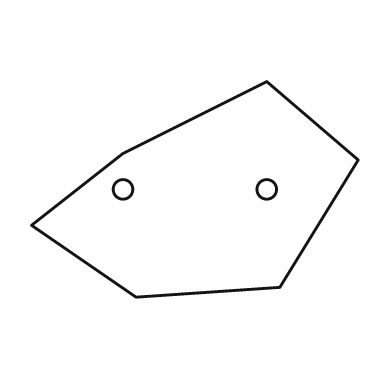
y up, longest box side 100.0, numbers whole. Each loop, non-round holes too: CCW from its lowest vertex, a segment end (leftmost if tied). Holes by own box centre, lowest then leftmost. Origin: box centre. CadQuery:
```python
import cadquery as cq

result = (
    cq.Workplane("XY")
    .moveTo(-18.0, -33.0)
    .lineTo(26.0, -30.0)
    .lineTo(50.0, 9.0)
    .lineTo(22.0, 33.0)
    .lineTo(-22.0, 11.0)
    .lineTo(-50.0, -11.0)
    .close()
    .moveTo(-22.0, 0.0)
    .circle(3.0)
    .moveTo(22.0, 0.0)
    .circle(3.0)
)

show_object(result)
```